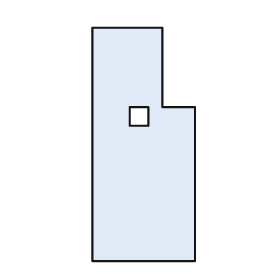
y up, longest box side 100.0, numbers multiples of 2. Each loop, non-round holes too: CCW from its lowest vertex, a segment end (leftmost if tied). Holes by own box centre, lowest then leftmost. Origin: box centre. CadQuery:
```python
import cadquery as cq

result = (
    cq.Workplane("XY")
    .moveTo(-22.0, -50.0)
    .lineTo(22.0, -50.0)
    .lineTo(22.0, 16.0)
    .lineTo(8.0, 16.0)
    .lineTo(8.0, 50.0)
    .lineTo(-22.0, 50.0)
    .close()
    .moveTo(-6.0, 8.0)
    .lineTo(2.0, 8.0)
    .lineTo(2.0, 16.0)
    .lineTo(-6.0, 16.0)
    .close()
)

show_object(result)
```